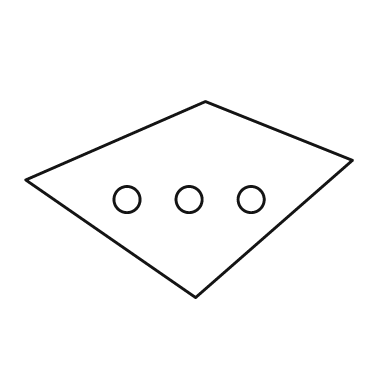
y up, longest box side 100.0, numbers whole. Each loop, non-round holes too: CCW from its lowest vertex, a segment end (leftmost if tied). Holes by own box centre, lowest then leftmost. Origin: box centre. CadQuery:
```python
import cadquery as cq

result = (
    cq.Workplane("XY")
    .moveTo(2.0, -30.0)
    .lineTo(50.0, 12.0)
    .lineTo(5.0, 30.0)
    .lineTo(-50.0, 6.0)
    .close()
    .moveTo(-19.0, 0.0)
    .circle(4.0)
    .moveTo(0.0, 0.0)
    .circle(4.0)
    .moveTo(19.0, 0.0)
    .circle(4.0)
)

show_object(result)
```